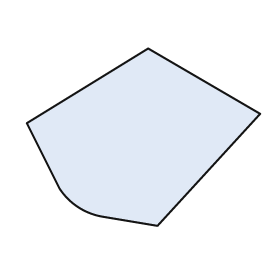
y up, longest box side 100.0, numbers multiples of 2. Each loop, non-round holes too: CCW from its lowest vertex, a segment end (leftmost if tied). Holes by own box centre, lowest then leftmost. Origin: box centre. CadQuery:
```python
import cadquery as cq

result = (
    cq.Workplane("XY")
    .moveTo(6.0, -38.0)
    .lineTo(50.0, 10.0)
    .lineTo(2.0, 38.0)
    .lineTo(-50.0, 6.0)
    .lineTo(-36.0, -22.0)
    .threePointArc((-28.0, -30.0), (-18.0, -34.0))
    .close()
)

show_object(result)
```